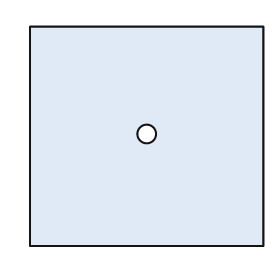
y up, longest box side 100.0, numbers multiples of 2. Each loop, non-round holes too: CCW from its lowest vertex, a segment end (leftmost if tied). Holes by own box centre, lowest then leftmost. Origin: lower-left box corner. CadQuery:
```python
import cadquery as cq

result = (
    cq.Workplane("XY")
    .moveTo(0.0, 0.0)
    .lineTo(100.0, 0.0)
    .lineTo(100.0, 94.0)
    .lineTo(0.0, 94.0)
    .close()
    .moveTo(50.0, 48.0)
    .circle(4.0)
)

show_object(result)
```